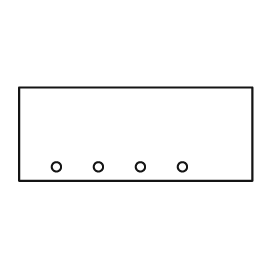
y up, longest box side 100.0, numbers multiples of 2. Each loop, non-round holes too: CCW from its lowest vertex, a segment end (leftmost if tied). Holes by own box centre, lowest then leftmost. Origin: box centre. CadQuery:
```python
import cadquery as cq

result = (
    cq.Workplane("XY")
    .moveTo(-50.0, -20.0)
    .lineTo(50.0, -20.0)
    .lineTo(50.0, 20.0)
    .lineTo(-50.0, 20.0)
    .close()
    .moveTo(-34.0, -14.0)
    .circle(2.0)
    .moveTo(-16.0, -14.0)
    .circle(2.0)
    .moveTo(2.0, -14.0)
    .circle(2.0)
    .moveTo(20.0, -14.0)
    .circle(2.0)
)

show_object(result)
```